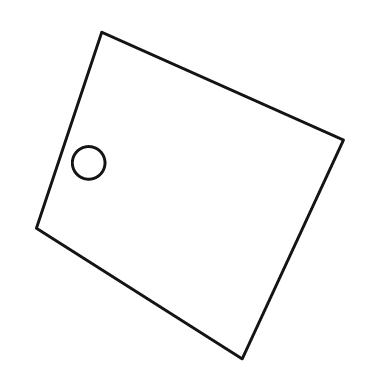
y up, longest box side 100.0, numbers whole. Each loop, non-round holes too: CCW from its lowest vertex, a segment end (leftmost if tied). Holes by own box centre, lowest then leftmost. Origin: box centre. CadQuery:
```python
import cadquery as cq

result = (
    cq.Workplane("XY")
    .moveTo(16.0, -50.0)
    .lineTo(47.0, 17.0)
    .lineTo(-27.0, 50.0)
    .lineTo(-47.0, -10.0)
    .close()
    .moveTo(-31.0, 10.0)
    .circle(5.0)
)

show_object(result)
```